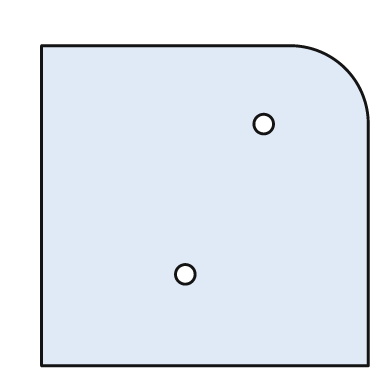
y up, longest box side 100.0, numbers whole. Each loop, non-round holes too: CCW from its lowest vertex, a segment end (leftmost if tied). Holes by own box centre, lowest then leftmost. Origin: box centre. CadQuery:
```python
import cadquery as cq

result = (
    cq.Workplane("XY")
    .moveTo(-50.0, -49.0)
    .lineTo(50.0, -49.0)
    .lineTo(50.0, 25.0)
    .threePointArc((43.0, 42.0), (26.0, 49.0))
    .lineTo(-50.0, 49.0)
    .close()
    .moveTo(-6.0, -21.0)
    .circle(3.0)
    .moveTo(18.0, 25.0)
    .circle(3.0)
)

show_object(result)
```